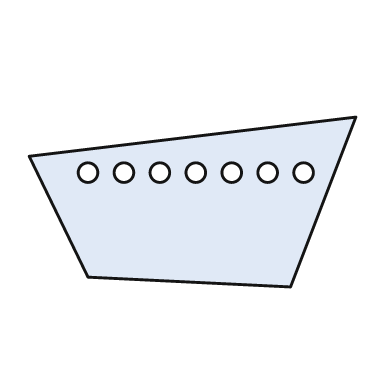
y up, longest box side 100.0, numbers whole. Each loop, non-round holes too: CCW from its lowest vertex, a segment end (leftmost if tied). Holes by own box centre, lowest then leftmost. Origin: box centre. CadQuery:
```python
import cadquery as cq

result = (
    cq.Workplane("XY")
    .moveTo(30.0, -26.0)
    .lineTo(50.0, 26.0)
    .lineTo(-50.0, 14.0)
    .lineTo(-32.0, -23.0)
    .close()
    .moveTo(-32.0, 9.0)
    .circle(3.0)
    .moveTo(-21.0, 9.0)
    .circle(3.0)
    .moveTo(-10.0, 9.0)
    .circle(3.0)
    .moveTo(1.0, 9.0)
    .circle(3.0)
    .moveTo(12.0, 9.0)
    .circle(3.0)
    .moveTo(23.0, 9.0)
    .circle(3.0)
    .moveTo(34.0, 9.0)
    .circle(3.0)
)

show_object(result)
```